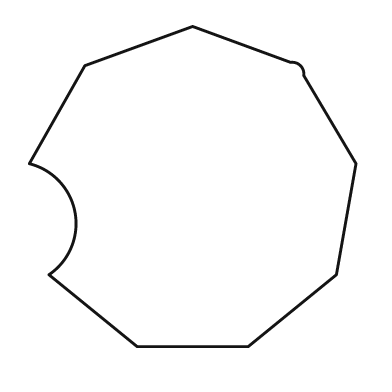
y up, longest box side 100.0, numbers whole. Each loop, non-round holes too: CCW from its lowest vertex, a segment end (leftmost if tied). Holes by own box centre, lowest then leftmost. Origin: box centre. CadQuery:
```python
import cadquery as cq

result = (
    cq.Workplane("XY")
    .moveTo(-17.0, -49.0)
    .lineTo(17.0, -49.0)
    .lineTo(44.0, -27.0)
    .lineTo(50.0, 7.0)
    .lineTo(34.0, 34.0)
    .threePointArc((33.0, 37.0), (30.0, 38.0))
    .lineTo(0.0, 49.0)
    .lineTo(-33.0, 37.0)
    .lineTo(-50.0, 7.0)
    .threePointArc((-36.0, -8.0), (-44.0, -27.0))
    .close()
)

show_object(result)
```